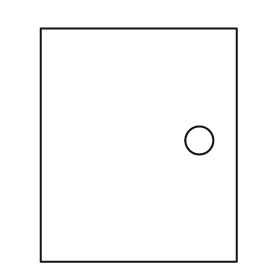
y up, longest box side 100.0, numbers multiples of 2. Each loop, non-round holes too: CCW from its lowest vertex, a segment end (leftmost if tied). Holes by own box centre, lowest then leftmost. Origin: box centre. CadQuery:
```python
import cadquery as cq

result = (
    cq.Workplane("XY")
    .moveTo(-42.0, -50.0)
    .lineTo(42.0, -50.0)
    .lineTo(42.0, 50.0)
    .lineTo(-42.0, 50.0)
    .close()
    .moveTo(26.0, 2.0)
    .circle(6.0)
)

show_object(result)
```